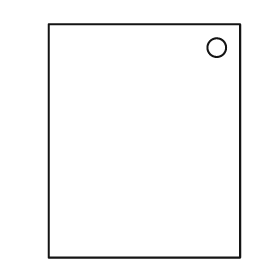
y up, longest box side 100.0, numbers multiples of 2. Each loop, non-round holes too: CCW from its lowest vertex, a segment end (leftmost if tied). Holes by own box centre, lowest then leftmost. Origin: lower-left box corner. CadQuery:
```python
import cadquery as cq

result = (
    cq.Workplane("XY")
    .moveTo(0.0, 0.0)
    .lineTo(82.0, 0.0)
    .lineTo(82.0, 100.0)
    .lineTo(0.0, 100.0)
    .close()
    .moveTo(72.0, 90.0)
    .circle(4.0)
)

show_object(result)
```